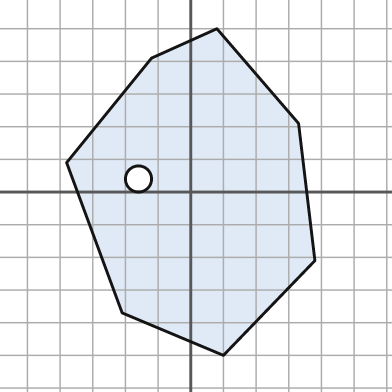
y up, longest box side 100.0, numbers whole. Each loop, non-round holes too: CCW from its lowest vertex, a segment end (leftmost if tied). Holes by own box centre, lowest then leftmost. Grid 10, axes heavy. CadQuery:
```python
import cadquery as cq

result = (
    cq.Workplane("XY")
    .moveTo(10.0, -50.0)
    .lineTo(38.0, -21.0)
    .lineTo(33.0, 21.0)
    .lineTo(8.0, 50.0)
    .lineTo(-12.0, 41.0)
    .lineTo(-38.0, 9.0)
    .lineTo(-21.0, -37.0)
    .close()
    .moveTo(-16.0, 4.0)
    .circle(4.0)
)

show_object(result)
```